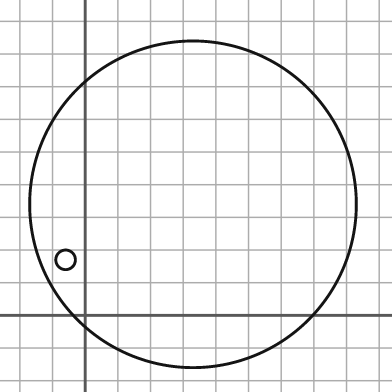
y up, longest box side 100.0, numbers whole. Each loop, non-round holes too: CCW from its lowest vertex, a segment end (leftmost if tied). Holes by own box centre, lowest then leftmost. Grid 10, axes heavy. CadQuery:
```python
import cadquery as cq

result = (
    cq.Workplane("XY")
    .moveTo(33.0, 34.0)
    .circle(50.0)
    .moveTo(-6.0, 17.0)
    .circle(3.0)
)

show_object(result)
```